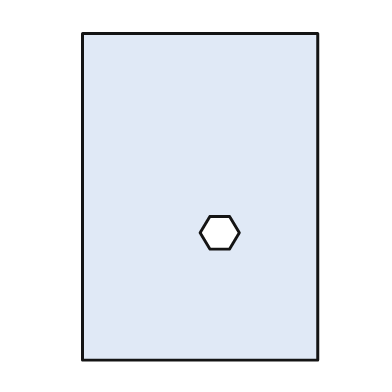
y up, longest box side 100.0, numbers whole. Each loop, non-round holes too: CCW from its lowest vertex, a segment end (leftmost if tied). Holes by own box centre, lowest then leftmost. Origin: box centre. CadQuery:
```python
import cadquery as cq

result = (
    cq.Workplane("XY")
    .moveTo(-36.0, -50.0)
    .lineTo(36.0, -50.0)
    .lineTo(36.0, 50.0)
    .lineTo(-36.0, 50.0)
    .close()
    .moveTo(3.0, -16.0)
    .lineTo(9.0, -16.0)
    .lineTo(12.0, -11.0)
    .lineTo(9.0, -6.0)
    .lineTo(3.0, -6.0)
    .lineTo(0.0, -11.0)
    .close()
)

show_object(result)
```